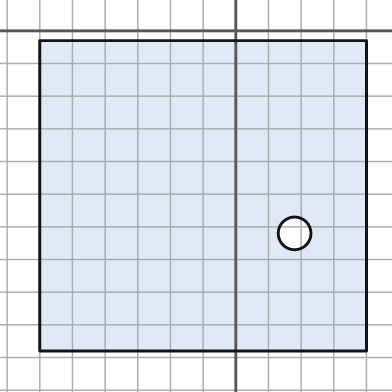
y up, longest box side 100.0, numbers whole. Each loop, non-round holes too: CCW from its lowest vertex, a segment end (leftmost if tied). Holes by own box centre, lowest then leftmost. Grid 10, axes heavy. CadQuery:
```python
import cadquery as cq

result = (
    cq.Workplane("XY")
    .moveTo(-60.0, -98.0)
    .lineTo(40.0, -98.0)
    .lineTo(40.0, -3.0)
    .lineTo(-60.0, -3.0)
    .close()
    .moveTo(18.0, -62.0)
    .circle(5.0)
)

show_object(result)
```